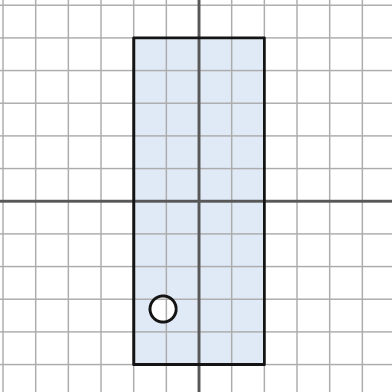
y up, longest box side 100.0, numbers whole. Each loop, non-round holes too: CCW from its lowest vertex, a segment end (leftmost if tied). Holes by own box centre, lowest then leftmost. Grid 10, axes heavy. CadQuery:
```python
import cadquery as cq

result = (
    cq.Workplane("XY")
    .moveTo(-20.0, -50.0)
    .lineTo(20.0, -50.0)
    .lineTo(20.0, 50.0)
    .lineTo(-20.0, 50.0)
    .close()
    .moveTo(-11.0, -33.0)
    .circle(4.0)
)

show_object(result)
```